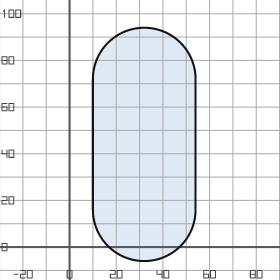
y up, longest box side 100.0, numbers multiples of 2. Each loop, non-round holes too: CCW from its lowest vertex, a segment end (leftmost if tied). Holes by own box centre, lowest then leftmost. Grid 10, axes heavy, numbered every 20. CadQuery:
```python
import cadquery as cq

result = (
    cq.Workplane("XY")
    .moveTo(10.0, 16.0)
    .threePointArc((32.0, -6.0), (54.0, 16.0))
    .lineTo(54.0, 72.0)
    .threePointArc((32.0, 94.0), (10.0, 72.0))
    .close()
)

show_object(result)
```